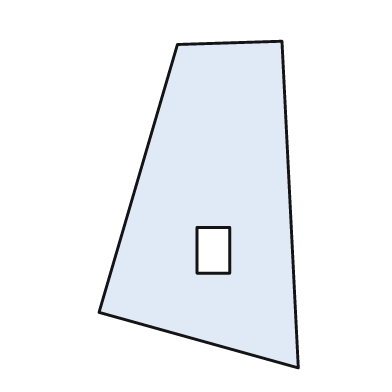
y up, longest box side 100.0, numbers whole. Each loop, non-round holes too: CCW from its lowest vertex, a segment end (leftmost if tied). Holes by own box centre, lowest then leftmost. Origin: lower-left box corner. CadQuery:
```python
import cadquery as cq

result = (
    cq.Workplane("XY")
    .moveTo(61.0, 0.0)
    .lineTo(56.0, 100.0)
    .lineTo(24.0, 99.0)
    .lineTo(0.0, 17.0)
    .close()
    .moveTo(30.0, 29.0)
    .lineTo(40.0, 29.0)
    .lineTo(40.0, 43.0)
    .lineTo(30.0, 43.0)
    .close()
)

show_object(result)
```